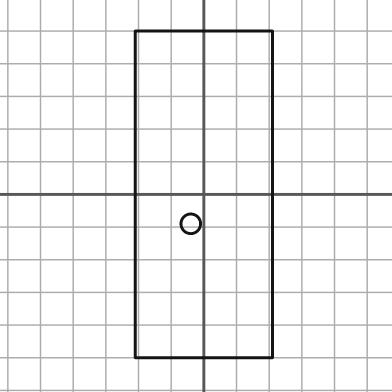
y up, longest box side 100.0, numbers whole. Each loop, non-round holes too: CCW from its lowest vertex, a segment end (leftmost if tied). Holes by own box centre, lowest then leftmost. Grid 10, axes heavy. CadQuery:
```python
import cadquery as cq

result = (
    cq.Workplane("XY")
    .moveTo(-21.0, -50.0)
    .lineTo(21.0, -50.0)
    .lineTo(21.0, 50.0)
    .lineTo(-21.0, 50.0)
    .close()
    .moveTo(-4.0, -9.0)
    .circle(3.0)
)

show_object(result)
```